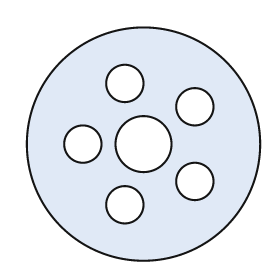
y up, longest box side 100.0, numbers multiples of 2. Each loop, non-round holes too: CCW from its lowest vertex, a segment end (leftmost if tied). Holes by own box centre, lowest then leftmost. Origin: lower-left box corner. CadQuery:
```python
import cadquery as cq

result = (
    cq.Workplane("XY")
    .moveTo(50.0, 50.0)
    .circle(50.0)
    .moveTo(42.0, 24.0)
    .circle(8.0)
    .moveTo(72.0, 34.0)
    .circle(8.0)
    .moveTo(24.0, 50.0)
    .circle(8.0)
    .moveTo(50.0, 50.0)
    .circle(12.0)
    .moveTo(72.0, 66.0)
    .circle(8.0)
    .moveTo(42.0, 76.0)
    .circle(8.0)
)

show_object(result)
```